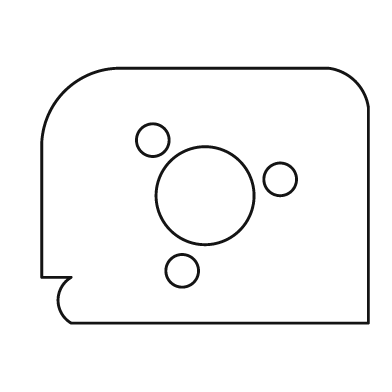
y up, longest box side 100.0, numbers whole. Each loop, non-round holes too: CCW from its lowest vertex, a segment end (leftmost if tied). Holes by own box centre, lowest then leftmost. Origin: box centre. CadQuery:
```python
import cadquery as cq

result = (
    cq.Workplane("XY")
    .moveTo(-41.0, -39.0)
    .lineTo(50.0, -39.0)
    .lineTo(50.0, 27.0)
    .threePointArc((46.0, 35.0), (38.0, 39.0))
    .lineTo(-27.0, 39.0)
    .threePointArc((-43.0, 32.0), (-50.0, 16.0))
    .lineTo(-50.0, -25.0)
    .lineTo(-41.0, -25.0)
    .threePointArc((-45.0, -32.0), (-41.0, -39.0))
    .close()
    .moveTo(-7.0, -23.0)
    .circle(5.0)
    .moveTo(0.0, 0.0)
    .circle(15.0)
    .moveTo(23.0, 5.0)
    .circle(5.0)
    .moveTo(-16.0, 17.0)
    .circle(5.0)
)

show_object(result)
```